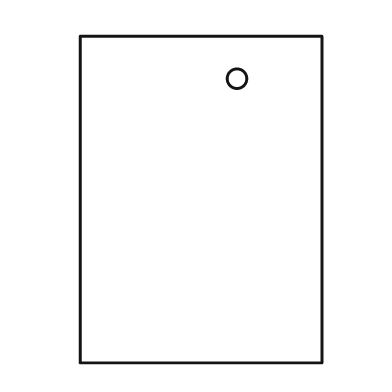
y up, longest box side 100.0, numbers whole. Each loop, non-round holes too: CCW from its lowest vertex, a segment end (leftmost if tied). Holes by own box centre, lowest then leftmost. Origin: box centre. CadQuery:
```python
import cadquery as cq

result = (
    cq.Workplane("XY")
    .moveTo(-37.0, -50.0)
    .lineTo(37.0, -50.0)
    .lineTo(37.0, 50.0)
    .lineTo(-37.0, 50.0)
    .close()
    .moveTo(11.0, 37.0)
    .circle(3.0)
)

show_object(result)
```